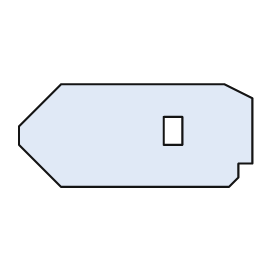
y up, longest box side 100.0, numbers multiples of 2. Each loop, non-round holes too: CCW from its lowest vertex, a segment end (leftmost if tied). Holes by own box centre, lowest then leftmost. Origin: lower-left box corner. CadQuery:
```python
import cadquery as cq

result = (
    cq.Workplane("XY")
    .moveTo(18.0, 0.0)
    .lineTo(90.0, 0.0)
    .lineTo(94.0, 4.0)
    .lineTo(94.0, 10.0)
    .lineTo(100.0, 10.0)
    .lineTo(100.0, 38.0)
    .lineTo(88.0, 44.0)
    .lineTo(18.0, 44.0)
    .lineTo(0.0, 26.0)
    .lineTo(0.0, 18.0)
    .close()
    .moveTo(62.0, 18.0)
    .lineTo(70.0, 18.0)
    .lineTo(70.0, 30.0)
    .lineTo(62.0, 30.0)
    .close()
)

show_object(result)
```